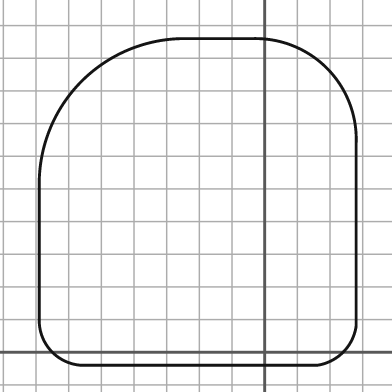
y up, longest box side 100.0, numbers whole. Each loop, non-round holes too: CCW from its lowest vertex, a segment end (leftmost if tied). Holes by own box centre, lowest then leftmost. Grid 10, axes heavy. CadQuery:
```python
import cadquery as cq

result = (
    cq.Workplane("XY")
    .moveTo(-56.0, -4.0)
    .lineTo(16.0, -4.0)
    .threePointArc((24.0, 0.0), (28.0, 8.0))
    .lineTo(28.0, 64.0)
    .threePointArc((19.0, 87.0), (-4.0, 96.0))
    .lineTo(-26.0, 96.0)
    .threePointArc((-56.0, 83.0), (-69.0, 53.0))
    .lineTo(-69.0, 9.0)
    .threePointArc((-65.0, 0.0), (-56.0, -4.0))
    .close()
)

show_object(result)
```